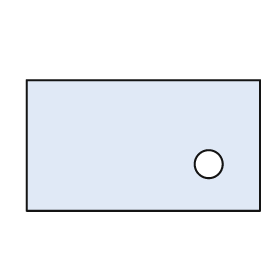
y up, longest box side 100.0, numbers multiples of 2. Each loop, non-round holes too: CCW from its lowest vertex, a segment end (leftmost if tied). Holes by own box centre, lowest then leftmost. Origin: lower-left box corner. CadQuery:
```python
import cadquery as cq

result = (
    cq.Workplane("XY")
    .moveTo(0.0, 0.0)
    .lineTo(100.0, 0.0)
    .lineTo(100.0, 56.0)
    .lineTo(0.0, 56.0)
    .close()
    .moveTo(78.0, 20.0)
    .circle(6.0)
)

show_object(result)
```